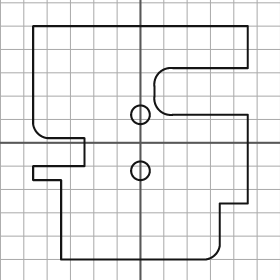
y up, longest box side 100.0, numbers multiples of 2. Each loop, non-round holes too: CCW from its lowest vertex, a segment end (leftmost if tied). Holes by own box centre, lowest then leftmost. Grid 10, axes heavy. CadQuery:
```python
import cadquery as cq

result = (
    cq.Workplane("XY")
    .moveTo(-34.0, -50.0)
    .lineTo(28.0, -50.0)
    .threePointArc((32.0, -48.0), (34.0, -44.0))
    .lineTo(34.0, -26.0)
    .lineTo(46.0, -26.0)
    .lineTo(46.0, 12.0)
    .lineTo(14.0, 12.0)
    .threePointArc((8.0, 14.0), (6.0, 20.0))
    .lineTo(6.0, 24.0)
    .threePointArc((8.0, 30.0), (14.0, 32.0))
    .lineTo(46.0, 32.0)
    .lineTo(46.0, 50.0)
    .lineTo(-46.0, 50.0)
    .lineTo(-46.0, 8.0)
    .threePointArc((-44.0, 4.0), (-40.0, 2.0))
    .lineTo(-24.0, 2.0)
    .lineTo(-24.0, -10.0)
    .lineTo(-46.0, -10.0)
    .lineTo(-46.0, -16.0)
    .lineTo(-34.0, -16.0)
    .close()
    .moveTo(0.0, -12.0)
    .circle(4.0)
    .moveTo(0.0, 12.0)
    .circle(4.0)
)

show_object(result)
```